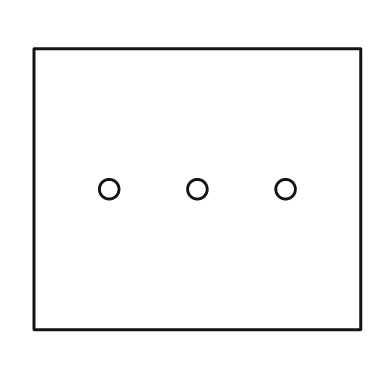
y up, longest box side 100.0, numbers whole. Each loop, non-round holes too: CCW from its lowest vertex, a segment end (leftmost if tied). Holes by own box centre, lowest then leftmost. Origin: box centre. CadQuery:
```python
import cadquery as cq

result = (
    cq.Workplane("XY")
    .moveTo(-50.0, -43.0)
    .lineTo(50.0, -43.0)
    .lineTo(50.0, 43.0)
    .lineTo(-50.0, 43.0)
    .close()
    .moveTo(-27.0, 0.0)
    .circle(3.0)
    .moveTo(0.0, 0.0)
    .circle(3.0)
    .moveTo(27.0, 0.0)
    .circle(3.0)
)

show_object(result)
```